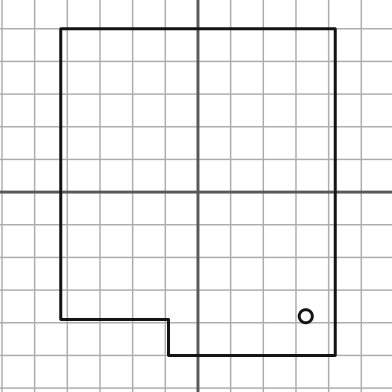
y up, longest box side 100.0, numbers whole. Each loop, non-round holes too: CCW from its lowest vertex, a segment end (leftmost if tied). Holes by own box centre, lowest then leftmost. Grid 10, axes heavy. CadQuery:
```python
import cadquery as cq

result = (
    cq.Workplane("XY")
    .moveTo(-9.0, -50.0)
    .lineTo(42.0, -50.0)
    .lineTo(42.0, 50.0)
    .lineTo(-42.0, 50.0)
    .lineTo(-42.0, -39.0)
    .lineTo(-9.0, -39.0)
    .close()
    .moveTo(33.0, -38.0)
    .circle(2.0)
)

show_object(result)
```